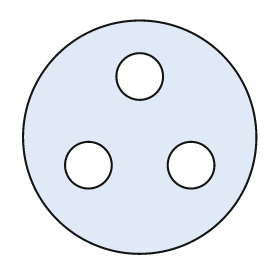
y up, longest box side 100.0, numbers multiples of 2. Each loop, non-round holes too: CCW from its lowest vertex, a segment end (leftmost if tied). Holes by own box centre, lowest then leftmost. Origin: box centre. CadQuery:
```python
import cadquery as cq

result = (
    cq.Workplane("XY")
    .moveTo(0.0, 0.0)
    .circle(50.0)
    .moveTo(-22.0, -12.0)
    .circle(10.0)
    .moveTo(22.0, -12.0)
    .circle(10.0)
    .moveTo(0.0, 26.0)
    .circle(10.0)
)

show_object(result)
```